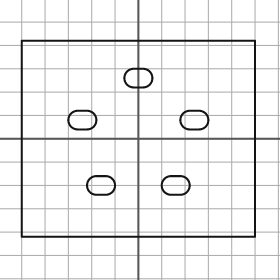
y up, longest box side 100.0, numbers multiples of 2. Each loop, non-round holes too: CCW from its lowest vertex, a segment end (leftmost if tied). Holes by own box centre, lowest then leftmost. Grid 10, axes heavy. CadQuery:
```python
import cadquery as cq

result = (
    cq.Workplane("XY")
    .moveTo(-50.0, -42.0)
    .lineTo(50.0, -42.0)
    .lineTo(50.0, 42.0)
    .lineTo(-50.0, 42.0)
    .close()
    .moveTo(-18.0, -24.0)
    .lineTo(-14.0, -24.0)
    .threePointArc((-10.0, -20.0), (-14.0, -16.0))
    .lineTo(-18.0, -16.0)
    .threePointArc((-22.0, -20.0), (-18.0, -24.0))
    .close()
    .moveTo(14.0, -24.0)
    .lineTo(18.0, -24.0)
    .threePointArc((22.0, -20.0), (18.0, -16.0))
    .lineTo(14.0, -16.0)
    .threePointArc((10.0, -20.0), (14.0, -24.0))
    .close()
    .moveTo(-26.0, 4.0)
    .lineTo(-22.0, 4.0)
    .threePointArc((-18.0, 8.0), (-22.0, 12.0))
    .lineTo(-26.0, 12.0)
    .threePointArc((-30.0, 8.0), (-26.0, 4.0))
    .close()
    .moveTo(22.0, 4.0)
    .lineTo(26.0, 4.0)
    .threePointArc((30.0, 8.0), (26.0, 12.0))
    .lineTo(22.0, 12.0)
    .threePointArc((18.0, 8.0), (22.0, 4.0))
    .close()
    .moveTo(-2.0, 22.0)
    .lineTo(2.0, 22.0)
    .threePointArc((6.0, 26.0), (2.0, 30.0))
    .lineTo(-2.0, 30.0)
    .threePointArc((-6.0, 26.0), (-2.0, 22.0))
    .close()
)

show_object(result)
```